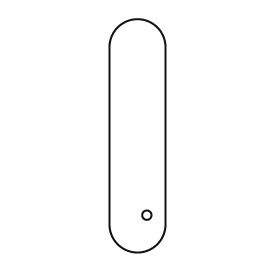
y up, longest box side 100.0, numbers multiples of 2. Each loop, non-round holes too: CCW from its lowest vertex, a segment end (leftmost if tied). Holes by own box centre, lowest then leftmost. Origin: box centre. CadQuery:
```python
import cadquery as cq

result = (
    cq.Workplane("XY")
    .moveTo(-12.0, -38.0)
    .threePointArc((0.0, -50.0), (12.0, -38.0))
    .lineTo(12.0, 38.0)
    .threePointArc((0.0, 50.0), (-12.0, 38.0))
    .close()
    .moveTo(4.0, -34.0)
    .circle(2.0)
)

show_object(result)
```